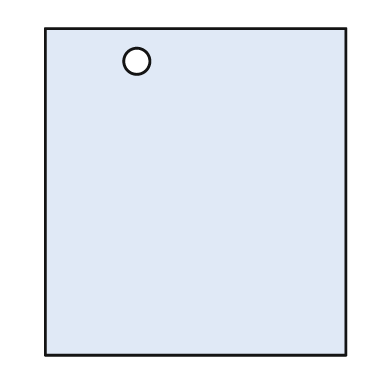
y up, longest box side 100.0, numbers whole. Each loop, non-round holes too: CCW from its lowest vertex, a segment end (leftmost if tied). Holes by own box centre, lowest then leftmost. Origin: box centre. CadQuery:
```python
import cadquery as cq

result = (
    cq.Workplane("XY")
    .moveTo(-46.0, -50.0)
    .lineTo(46.0, -50.0)
    .lineTo(46.0, 50.0)
    .lineTo(-46.0, 50.0)
    .close()
    .moveTo(-18.0, 40.0)
    .circle(4.0)
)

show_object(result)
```